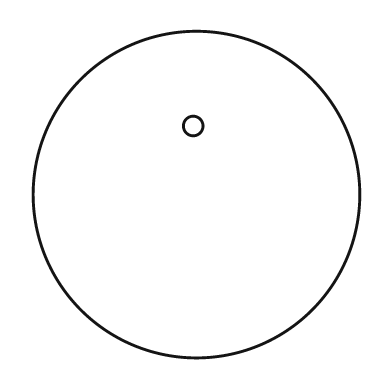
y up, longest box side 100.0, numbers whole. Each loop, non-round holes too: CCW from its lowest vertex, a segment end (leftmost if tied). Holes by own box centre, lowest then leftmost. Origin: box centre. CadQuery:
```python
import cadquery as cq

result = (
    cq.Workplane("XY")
    .moveTo(0.0, 0.0)
    .circle(50.0)
    .moveTo(-1.0, 21.0)
    .circle(3.0)
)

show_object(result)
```